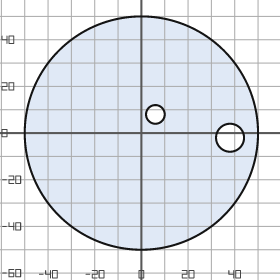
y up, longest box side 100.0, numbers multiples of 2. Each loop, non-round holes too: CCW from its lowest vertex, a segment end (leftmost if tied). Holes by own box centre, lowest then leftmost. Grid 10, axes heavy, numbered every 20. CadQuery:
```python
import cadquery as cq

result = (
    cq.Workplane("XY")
    .moveTo(0.0, 0.0)
    .circle(50.0)
    .moveTo(38.0, -2.0)
    .circle(6.0)
    .moveTo(6.0, 8.0)
    .circle(4.0)
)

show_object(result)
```